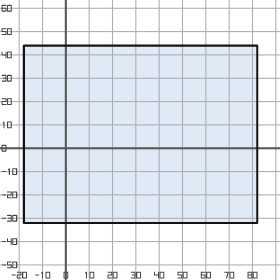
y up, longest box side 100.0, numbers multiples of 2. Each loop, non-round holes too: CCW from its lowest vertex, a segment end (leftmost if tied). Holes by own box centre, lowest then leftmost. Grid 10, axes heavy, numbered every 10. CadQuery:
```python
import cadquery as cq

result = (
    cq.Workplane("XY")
    .moveTo(-18.0, -32.0)
    .lineTo(82.0, -32.0)
    .lineTo(82.0, 44.0)
    .lineTo(-18.0, 44.0)
    .close()
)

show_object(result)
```